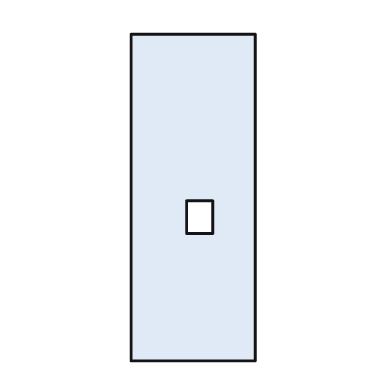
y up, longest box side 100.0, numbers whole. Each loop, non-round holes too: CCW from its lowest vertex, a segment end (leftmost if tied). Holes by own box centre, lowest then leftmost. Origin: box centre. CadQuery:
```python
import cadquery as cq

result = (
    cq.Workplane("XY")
    .moveTo(-19.0, -50.0)
    .lineTo(19.0, -50.0)
    .lineTo(19.0, 50.0)
    .lineTo(-19.0, 50.0)
    .close()
    .moveTo(-2.0, -11.0)
    .lineTo(6.0, -11.0)
    .lineTo(6.0, -1.0)
    .lineTo(-2.0, -1.0)
    .close()
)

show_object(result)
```